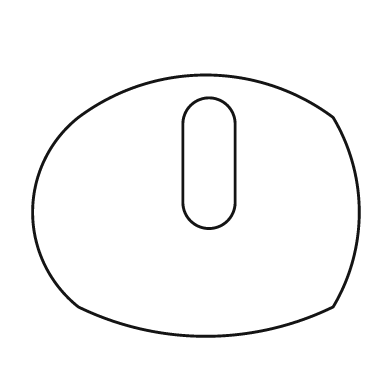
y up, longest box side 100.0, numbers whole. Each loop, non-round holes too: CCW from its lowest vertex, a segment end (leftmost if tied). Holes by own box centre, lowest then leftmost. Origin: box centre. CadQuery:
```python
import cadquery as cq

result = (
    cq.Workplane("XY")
    .moveTo(-36.0, -31.0)
    .threePointArc((3.0, -40.0), (42.0, -31.0))
    .threePointArc((50.0, -2.0), (42.0, 27.0))
    .threePointArc((3.0, 40.0), (-36.0, 27.0))
    .threePointArc((-50.0, -2.0), (-36.0, -31.0))
    .close()
    .moveTo(-4.0, 1.0)
    .threePointArc((4.0, -7.0), (12.0, 1.0))
    .lineTo(12.0, 25.0)
    .threePointArc((4.0, 33.0), (-4.0, 25.0))
    .close()
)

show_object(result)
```